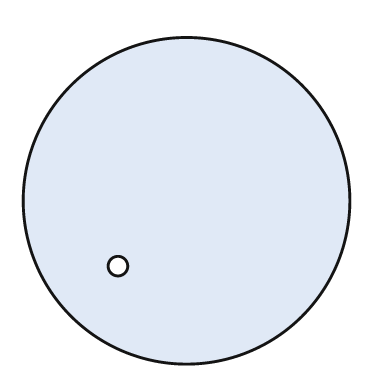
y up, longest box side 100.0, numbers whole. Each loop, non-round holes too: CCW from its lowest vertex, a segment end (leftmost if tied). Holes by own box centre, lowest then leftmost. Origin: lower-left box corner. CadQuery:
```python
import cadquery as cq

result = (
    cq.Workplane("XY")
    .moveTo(50.0, 50.0)
    .circle(50.0)
    .moveTo(29.0, 30.0)
    .circle(3.0)
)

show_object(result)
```